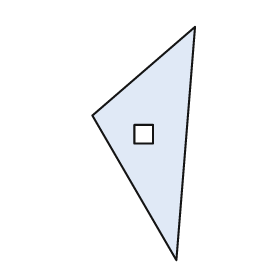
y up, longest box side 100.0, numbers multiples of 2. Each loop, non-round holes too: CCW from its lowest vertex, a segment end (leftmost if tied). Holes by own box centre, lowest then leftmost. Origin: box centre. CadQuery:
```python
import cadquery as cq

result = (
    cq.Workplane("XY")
    .moveTo(14.0, -50.0)
    .lineTo(22.0, 50.0)
    .lineTo(-22.0, 12.0)
    .close()
    .moveTo(-4.0, 0.0)
    .lineTo(4.0, 0.0)
    .lineTo(4.0, 8.0)
    .lineTo(-4.0, 8.0)
    .close()
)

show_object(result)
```